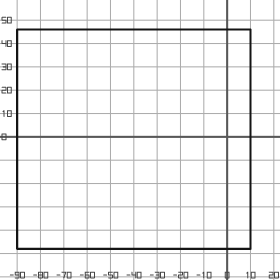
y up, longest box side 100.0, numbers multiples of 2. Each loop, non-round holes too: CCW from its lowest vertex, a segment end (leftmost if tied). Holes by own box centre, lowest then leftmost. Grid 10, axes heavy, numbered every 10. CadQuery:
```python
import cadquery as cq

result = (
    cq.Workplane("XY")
    .moveTo(-90.0, -48.0)
    .lineTo(10.0, -48.0)
    .lineTo(10.0, 46.0)
    .lineTo(-90.0, 46.0)
    .close()
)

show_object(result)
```